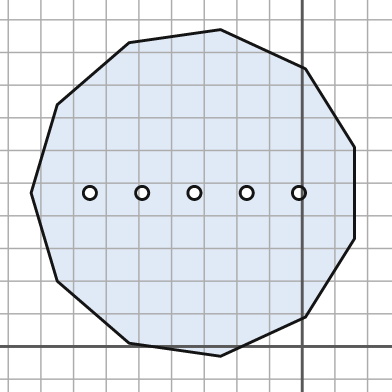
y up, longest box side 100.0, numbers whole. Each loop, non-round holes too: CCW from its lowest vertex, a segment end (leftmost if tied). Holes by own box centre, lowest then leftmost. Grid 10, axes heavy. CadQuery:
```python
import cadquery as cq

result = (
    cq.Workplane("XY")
    .moveTo(-25.0, -3.0)
    .lineTo(1.0, 9.0)
    .lineTo(16.0, 33.0)
    .lineTo(16.0, 61.0)
    .lineTo(1.0, 85.0)
    .lineTo(-25.0, 97.0)
    .lineTo(-53.0, 93.0)
    .lineTo(-75.0, 74.0)
    .lineTo(-83.0, 47.0)
    .lineTo(-75.0, 20.0)
    .lineTo(-53.0, 1.0)
    .close()
    .moveTo(-65.0, 47.0)
    .circle(2.0)
    .moveTo(-49.0, 47.0)
    .circle(2.0)
    .moveTo(-33.0, 47.0)
    .circle(2.0)
    .moveTo(-17.0, 47.0)
    .circle(2.0)
    .moveTo(-1.0, 47.0)
    .circle(2.0)
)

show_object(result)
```